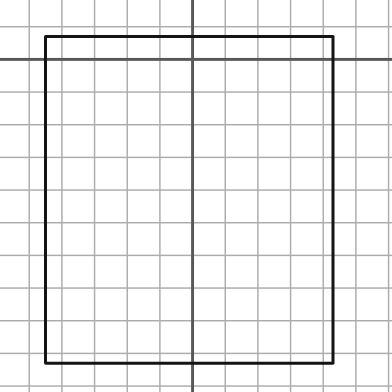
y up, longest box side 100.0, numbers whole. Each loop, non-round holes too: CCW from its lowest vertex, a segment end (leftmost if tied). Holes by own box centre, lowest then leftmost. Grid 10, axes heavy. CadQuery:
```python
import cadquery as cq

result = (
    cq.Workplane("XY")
    .moveTo(-45.0, -93.0)
    .lineTo(43.0, -93.0)
    .lineTo(43.0, 7.0)
    .lineTo(-45.0, 7.0)
    .close()
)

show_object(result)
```